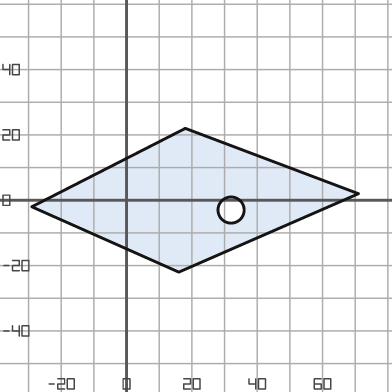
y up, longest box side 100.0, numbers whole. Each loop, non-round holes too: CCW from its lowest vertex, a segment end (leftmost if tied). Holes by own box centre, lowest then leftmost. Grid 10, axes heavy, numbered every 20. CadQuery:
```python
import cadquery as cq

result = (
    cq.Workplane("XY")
    .moveTo(16.0, -22.0)
    .lineTo(71.0, 2.0)
    .lineTo(18.0, 22.0)
    .lineTo(-29.0, -2.0)
    .close()
    .moveTo(32.0, -3.0)
    .circle(4.0)
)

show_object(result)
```